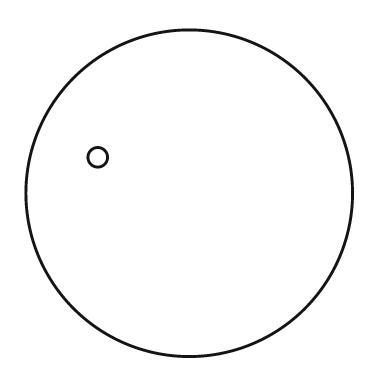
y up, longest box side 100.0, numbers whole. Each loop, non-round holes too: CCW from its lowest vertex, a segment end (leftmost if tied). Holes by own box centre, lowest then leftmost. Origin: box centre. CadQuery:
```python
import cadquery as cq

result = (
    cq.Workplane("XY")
    .moveTo(0.0, 0.0)
    .circle(50.0)
    .moveTo(-28.0, 11.0)
    .circle(3.0)
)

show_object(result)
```